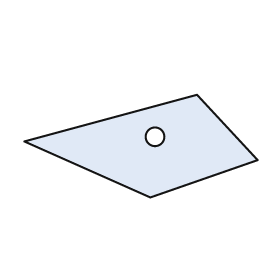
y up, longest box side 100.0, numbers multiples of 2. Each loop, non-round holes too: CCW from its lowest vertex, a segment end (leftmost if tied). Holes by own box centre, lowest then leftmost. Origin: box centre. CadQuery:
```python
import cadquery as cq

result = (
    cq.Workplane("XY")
    .moveTo(4.0, -22.0)
    .lineTo(50.0, -6.0)
    .lineTo(24.0, 22.0)
    .lineTo(-50.0, 2.0)
    .close()
    .moveTo(6.0, 4.0)
    .circle(4.0)
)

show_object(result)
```